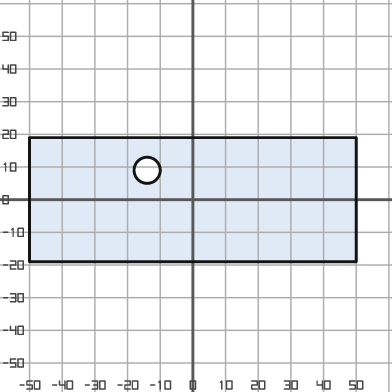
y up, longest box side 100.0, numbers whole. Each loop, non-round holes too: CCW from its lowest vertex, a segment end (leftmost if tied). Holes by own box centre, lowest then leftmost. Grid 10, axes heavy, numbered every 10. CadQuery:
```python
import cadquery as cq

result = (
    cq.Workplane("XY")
    .moveTo(-50.0, -19.0)
    .lineTo(50.0, -19.0)
    .lineTo(50.0, 19.0)
    .lineTo(-50.0, 19.0)
    .close()
    .moveTo(-14.0, 9.0)
    .circle(4.0)
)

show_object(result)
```